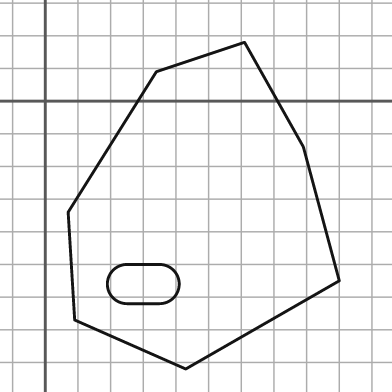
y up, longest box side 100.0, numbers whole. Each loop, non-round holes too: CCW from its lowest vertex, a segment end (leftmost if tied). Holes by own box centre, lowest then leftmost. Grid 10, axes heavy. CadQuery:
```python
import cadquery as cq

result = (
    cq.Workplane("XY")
    .moveTo(43.0, -82.0)
    .lineTo(90.0, -55.0)
    .lineTo(79.0, -14.0)
    .lineTo(61.0, 18.0)
    .lineTo(34.0, 9.0)
    .lineTo(7.0, -34.0)
    .lineTo(9.0, -67.0)
    .close()
    .moveTo(25.0, -62.0)
    .lineTo(35.0, -62.0)
    .threePointArc((41.0, -56.0), (35.0, -50.0))
    .lineTo(25.0, -50.0)
    .threePointArc((19.0, -56.0), (25.0, -62.0))
    .close()
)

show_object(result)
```